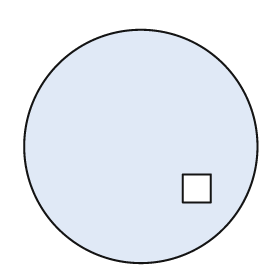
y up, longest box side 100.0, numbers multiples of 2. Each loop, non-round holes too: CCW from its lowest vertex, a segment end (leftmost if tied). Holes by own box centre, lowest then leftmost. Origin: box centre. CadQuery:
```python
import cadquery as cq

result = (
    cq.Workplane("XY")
    .moveTo(0.0, 0.0)
    .circle(50.0)
    .moveTo(18.0, -24.0)
    .lineTo(30.0, -24.0)
    .lineTo(30.0, -12.0)
    .lineTo(18.0, -12.0)
    .close()
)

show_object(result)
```